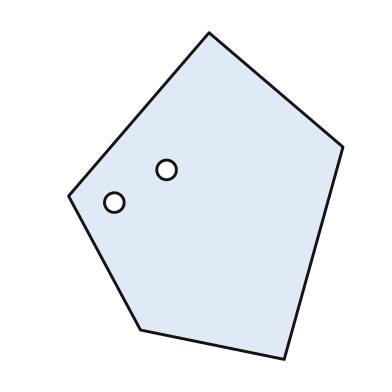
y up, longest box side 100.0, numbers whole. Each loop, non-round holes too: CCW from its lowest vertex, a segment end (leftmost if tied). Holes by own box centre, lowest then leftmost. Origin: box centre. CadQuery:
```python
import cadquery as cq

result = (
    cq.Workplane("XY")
    .moveTo(24.0, -50.0)
    .lineTo(42.0, 15.0)
    .lineTo(1.0, 50.0)
    .lineTo(-42.0, 0.0)
    .lineTo(-20.0, -41.0)
    .close()
    .moveTo(-28.0, -2.0)
    .circle(3.0)
    .moveTo(-12.0, 8.0)
    .circle(3.0)
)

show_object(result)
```